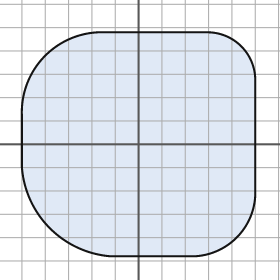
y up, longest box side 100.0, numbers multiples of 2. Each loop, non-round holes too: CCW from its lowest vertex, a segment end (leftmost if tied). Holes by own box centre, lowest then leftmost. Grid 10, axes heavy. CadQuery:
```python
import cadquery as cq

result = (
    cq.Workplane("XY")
    .moveTo(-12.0, -48.0)
    .lineTo(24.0, -48.0)
    .threePointArc((42.0, -40.0), (50.0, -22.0))
    .lineTo(50.0, 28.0)
    .threePointArc((44.0, 42.0), (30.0, 48.0))
    .lineTo(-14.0, 48.0)
    .threePointArc((-40.0, 38.0), (-50.0, 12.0))
    .lineTo(-50.0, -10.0)
    .threePointArc((-38.0, -36.0), (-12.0, -48.0))
    .close()
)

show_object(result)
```